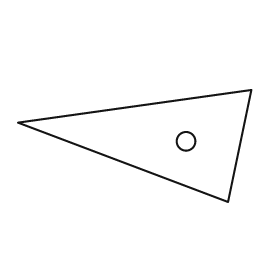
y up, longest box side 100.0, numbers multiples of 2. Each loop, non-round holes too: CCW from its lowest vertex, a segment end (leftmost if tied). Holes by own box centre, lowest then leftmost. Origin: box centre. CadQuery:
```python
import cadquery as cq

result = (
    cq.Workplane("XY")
    .moveTo(40.0, -24.0)
    .lineTo(50.0, 24.0)
    .lineTo(-50.0, 10.0)
    .close()
    .moveTo(22.0, 2.0)
    .circle(4.0)
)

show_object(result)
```